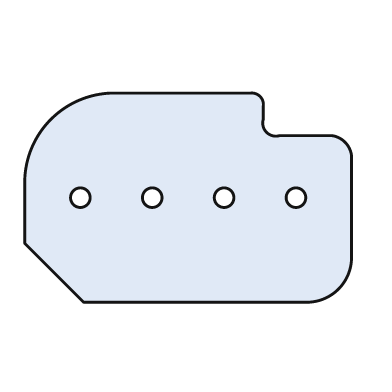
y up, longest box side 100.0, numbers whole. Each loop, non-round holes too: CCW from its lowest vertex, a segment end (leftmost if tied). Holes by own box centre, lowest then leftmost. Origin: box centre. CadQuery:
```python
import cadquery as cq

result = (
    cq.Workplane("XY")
    .moveTo(-32.0, -32.0)
    .lineTo(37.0, -32.0)
    .threePointArc((46.0, -28.0), (50.0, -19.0))
    .lineTo(50.0, 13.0)
    .threePointArc((48.0, 17.0), (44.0, 19.0))
    .lineTo(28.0, 19.0)
    .threePointArc((24.0, 20.0), (23.0, 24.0))
    .lineTo(23.0, 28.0)
    .threePointArc((22.0, 31.0), (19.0, 32.0))
    .lineTo(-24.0, 32.0)
    .threePointArc((-42.0, 24.0), (-50.0, 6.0))
    .lineTo(-50.0, -14.0)
    .close()
    .moveTo(-33.0, 0.0)
    .circle(3.0)
    .moveTo(-11.0, 0.0)
    .circle(3.0)
    .moveTo(11.0, 0.0)
    .circle(3.0)
    .moveTo(33.0, 0.0)
    .circle(3.0)
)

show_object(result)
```